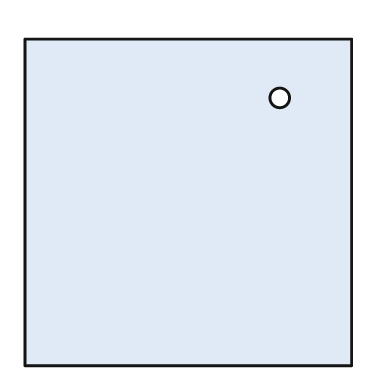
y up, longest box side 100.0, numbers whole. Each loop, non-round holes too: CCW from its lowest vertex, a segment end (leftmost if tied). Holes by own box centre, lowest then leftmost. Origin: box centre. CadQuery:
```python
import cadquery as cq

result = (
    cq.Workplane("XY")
    .moveTo(-50.0, -50.0)
    .lineTo(50.0, -50.0)
    .lineTo(50.0, 50.0)
    .lineTo(-50.0, 50.0)
    .close()
    .moveTo(28.0, 32.0)
    .circle(3.0)
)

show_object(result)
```